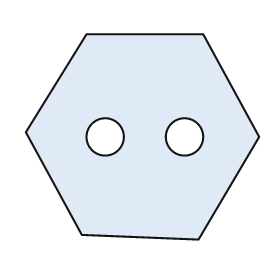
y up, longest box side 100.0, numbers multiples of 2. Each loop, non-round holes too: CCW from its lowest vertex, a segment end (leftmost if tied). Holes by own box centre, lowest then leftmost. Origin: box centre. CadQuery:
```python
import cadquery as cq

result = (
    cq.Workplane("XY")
    .moveTo(24.0, -44.0)
    .lineTo(50.0, 0.0)
    .lineTo(26.0, 44.0)
    .lineTo(-24.0, 44.0)
    .lineTo(-50.0, 2.0)
    .lineTo(-26.0, -42.0)
    .close()
    .moveTo(-16.0, 0.0)
    .circle(8.0)
    .moveTo(18.0, 0.0)
    .circle(8.0)
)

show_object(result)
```